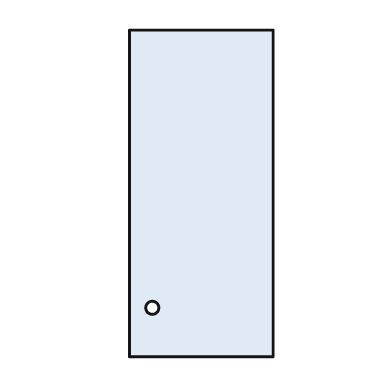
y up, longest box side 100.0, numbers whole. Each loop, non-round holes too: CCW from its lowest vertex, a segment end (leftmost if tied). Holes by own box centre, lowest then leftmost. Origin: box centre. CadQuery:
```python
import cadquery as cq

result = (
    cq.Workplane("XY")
    .moveTo(-22.0, -50.0)
    .lineTo(22.0, -50.0)
    .lineTo(22.0, 50.0)
    .lineTo(-22.0, 50.0)
    .close()
    .moveTo(-15.0, -35.0)
    .circle(2.0)
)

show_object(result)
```